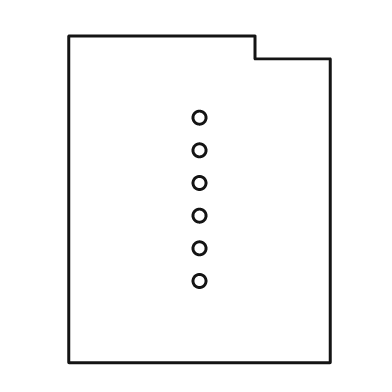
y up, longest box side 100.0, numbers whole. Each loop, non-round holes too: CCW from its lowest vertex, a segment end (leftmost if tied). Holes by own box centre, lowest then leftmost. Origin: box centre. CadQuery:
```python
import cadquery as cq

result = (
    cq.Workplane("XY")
    .moveTo(-40.0, -50.0)
    .lineTo(40.0, -50.0)
    .lineTo(40.0, 43.0)
    .lineTo(17.0, 43.0)
    .lineTo(17.0, 50.0)
    .lineTo(-40.0, 50.0)
    .close()
    .moveTo(0.0, -25.0)
    .circle(2.0)
    .moveTo(0.0, -15.0)
    .circle(2.0)
    .moveTo(0.0, -5.0)
    .circle(2.0)
    .moveTo(0.0, 5.0)
    .circle(2.0)
    .moveTo(0.0, 15.0)
    .circle(2.0)
    .moveTo(0.0, 25.0)
    .circle(2.0)
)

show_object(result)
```